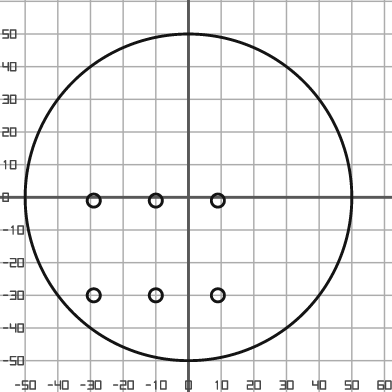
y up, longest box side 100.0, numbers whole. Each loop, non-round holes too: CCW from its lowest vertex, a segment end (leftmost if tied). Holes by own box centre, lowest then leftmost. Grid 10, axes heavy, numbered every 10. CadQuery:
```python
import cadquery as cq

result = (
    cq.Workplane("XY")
    .moveTo(0.0, 0.0)
    .circle(50.0)
    .moveTo(-29.0, -30.0)
    .circle(2.0)
    .moveTo(-10.0, -30.0)
    .circle(2.0)
    .moveTo(9.0, -30.0)
    .circle(2.0)
    .moveTo(-29.0, -1.0)
    .circle(2.0)
    .moveTo(-10.0, -1.0)
    .circle(2.0)
    .moveTo(9.0, -1.0)
    .circle(2.0)
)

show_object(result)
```